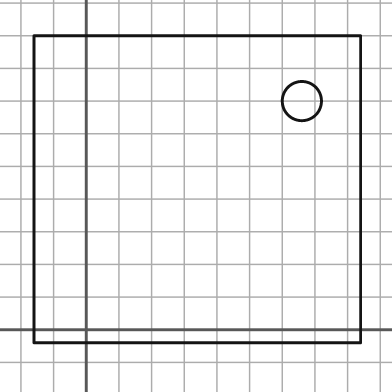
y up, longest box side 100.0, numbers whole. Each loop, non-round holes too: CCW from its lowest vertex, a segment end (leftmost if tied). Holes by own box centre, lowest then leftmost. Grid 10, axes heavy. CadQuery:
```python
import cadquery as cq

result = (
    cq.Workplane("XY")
    .moveTo(-16.0, -4.0)
    .lineTo(84.0, -4.0)
    .lineTo(84.0, 90.0)
    .lineTo(-16.0, 90.0)
    .close()
    .moveTo(66.0, 70.0)
    .circle(6.0)
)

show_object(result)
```